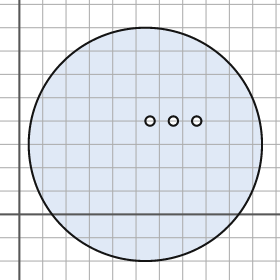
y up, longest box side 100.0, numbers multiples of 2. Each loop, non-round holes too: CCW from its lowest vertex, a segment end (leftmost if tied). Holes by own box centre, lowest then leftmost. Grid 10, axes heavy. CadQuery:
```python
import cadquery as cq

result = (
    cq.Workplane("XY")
    .moveTo(54.0, 30.0)
    .circle(50.0)
    .moveTo(56.0, 40.0)
    .circle(2.0)
    .moveTo(66.0, 40.0)
    .circle(2.0)
    .moveTo(76.0, 40.0)
    .circle(2.0)
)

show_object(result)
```